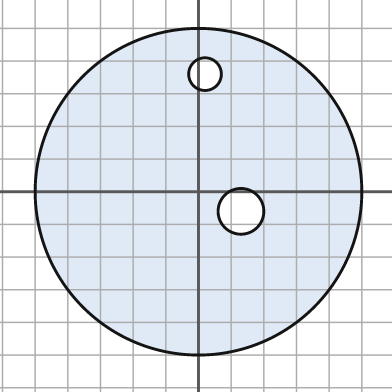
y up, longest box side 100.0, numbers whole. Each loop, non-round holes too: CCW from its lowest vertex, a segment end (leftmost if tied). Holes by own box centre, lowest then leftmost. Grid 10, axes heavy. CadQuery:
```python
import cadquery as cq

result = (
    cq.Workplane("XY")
    .moveTo(0.0, 0.0)
    .circle(50.0)
    .moveTo(13.0, -6.0)
    .circle(7.0)
    .moveTo(2.0, 36.0)
    .circle(5.0)
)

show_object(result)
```